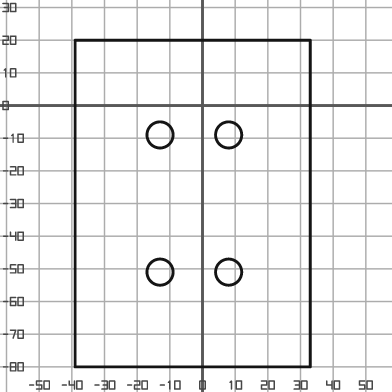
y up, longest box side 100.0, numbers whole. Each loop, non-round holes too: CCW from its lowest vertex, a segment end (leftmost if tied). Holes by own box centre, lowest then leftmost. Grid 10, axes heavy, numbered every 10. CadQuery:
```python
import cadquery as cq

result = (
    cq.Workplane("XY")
    .moveTo(-39.0, -80.0)
    .lineTo(33.0, -80.0)
    .lineTo(33.0, 20.0)
    .lineTo(-39.0, 20.0)
    .close()
    .moveTo(-13.0, -51.0)
    .circle(4.0)
    .moveTo(8.0, -51.0)
    .circle(4.0)
    .moveTo(-13.0, -9.0)
    .circle(4.0)
    .moveTo(8.0, -9.0)
    .circle(4.0)
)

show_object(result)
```